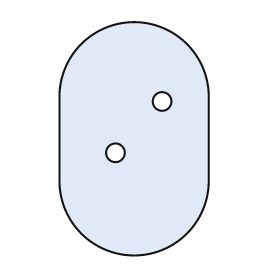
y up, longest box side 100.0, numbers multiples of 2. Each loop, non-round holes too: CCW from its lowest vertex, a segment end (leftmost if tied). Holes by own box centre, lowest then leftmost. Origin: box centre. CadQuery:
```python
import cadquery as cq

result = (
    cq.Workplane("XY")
    .moveTo(-32.0, -18.0)
    .threePointArc((0.0, -50.0), (32.0, -18.0))
    .lineTo(32.0, 18.0)
    .threePointArc((0.0, 50.0), (-32.0, 18.0))
    .close()
    .moveTo(-8.0, -6.0)
    .circle(4.0)
    .moveTo(12.0, 16.0)
    .circle(4.0)
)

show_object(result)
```